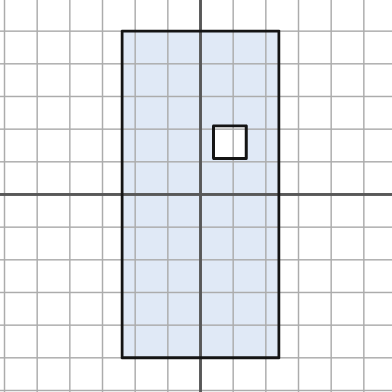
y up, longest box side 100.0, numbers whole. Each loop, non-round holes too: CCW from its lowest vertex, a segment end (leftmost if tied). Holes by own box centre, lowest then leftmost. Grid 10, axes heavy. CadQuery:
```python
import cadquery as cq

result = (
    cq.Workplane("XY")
    .moveTo(-24.0, -50.0)
    .lineTo(24.0, -50.0)
    .lineTo(24.0, 50.0)
    .lineTo(-24.0, 50.0)
    .close()
    .moveTo(4.0, 11.0)
    .lineTo(14.0, 11.0)
    .lineTo(14.0, 21.0)
    .lineTo(4.0, 21.0)
    .close()
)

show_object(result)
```